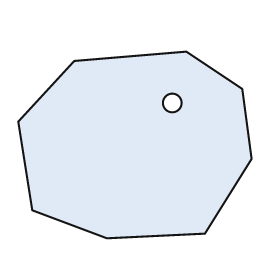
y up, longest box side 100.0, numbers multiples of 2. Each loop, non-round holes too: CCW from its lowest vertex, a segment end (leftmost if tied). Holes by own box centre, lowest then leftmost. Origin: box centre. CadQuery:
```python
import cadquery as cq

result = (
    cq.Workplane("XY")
    .moveTo(-12.0, -40.0)
    .lineTo(30.0, -38.0)
    .lineTo(50.0, -6.0)
    .lineTo(46.0, 24.0)
    .lineTo(22.0, 40.0)
    .lineTo(-26.0, 36.0)
    .lineTo(-50.0, 10.0)
    .lineTo(-44.0, -28.0)
    .close()
    .moveTo(16.0, 18.0)
    .circle(4.0)
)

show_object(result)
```